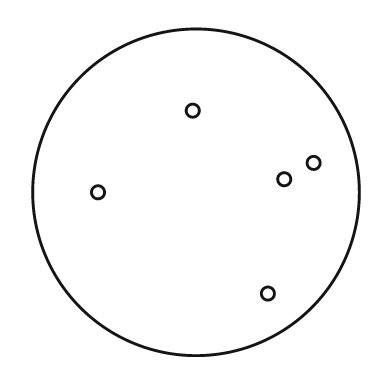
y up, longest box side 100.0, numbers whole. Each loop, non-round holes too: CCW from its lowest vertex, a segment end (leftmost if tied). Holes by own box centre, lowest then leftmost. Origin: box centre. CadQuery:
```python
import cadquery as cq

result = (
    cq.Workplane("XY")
    .moveTo(0.0, 0.0)
    .circle(50.0)
    .moveTo(22.0, -31.0)
    .circle(2.0)
    .moveTo(-30.0, 0.0)
    .circle(2.0)
    .moveTo(27.0, 4.0)
    .circle(2.0)
    .moveTo(36.0, 9.0)
    .circle(2.0)
    .moveTo(-1.0, 25.0)
    .circle(2.0)
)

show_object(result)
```